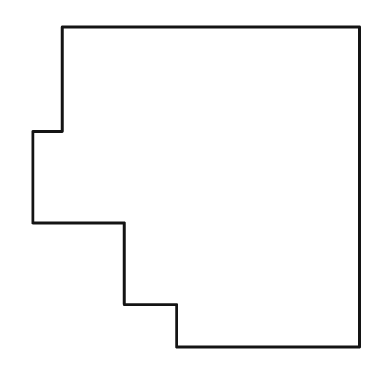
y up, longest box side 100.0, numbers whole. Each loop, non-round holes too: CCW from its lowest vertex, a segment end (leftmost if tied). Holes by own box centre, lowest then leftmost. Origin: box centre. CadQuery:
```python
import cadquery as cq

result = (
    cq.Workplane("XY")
    .moveTo(-6.0, -49.0)
    .lineTo(50.0, -49.0)
    .lineTo(50.0, 49.0)
    .lineTo(-41.0, 49.0)
    .lineTo(-41.0, 17.0)
    .lineTo(-50.0, 17.0)
    .lineTo(-50.0, -11.0)
    .lineTo(-22.0, -11.0)
    .lineTo(-22.0, -36.0)
    .lineTo(-6.0, -36.0)
    .close()
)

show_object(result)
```